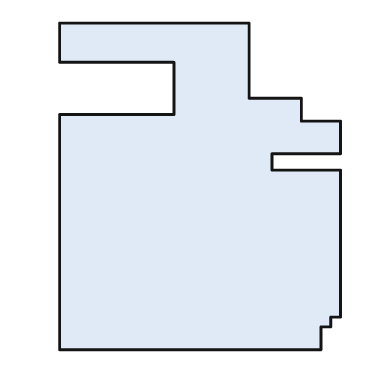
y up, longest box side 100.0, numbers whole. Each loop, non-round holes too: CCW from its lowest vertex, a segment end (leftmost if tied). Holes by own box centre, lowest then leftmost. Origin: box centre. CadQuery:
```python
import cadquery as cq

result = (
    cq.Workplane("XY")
    .moveTo(-43.0, -50.0)
    .lineTo(37.0, -50.0)
    .lineTo(37.0, -43.0)
    .lineTo(40.0, -43.0)
    .lineTo(40.0, -40.0)
    .lineTo(43.0, -40.0)
    .lineTo(43.0, 5.0)
    .lineTo(22.0, 5.0)
    .lineTo(22.0, 10.0)
    .lineTo(43.0, 10.0)
    .lineTo(43.0, 20.0)
    .lineTo(31.0, 20.0)
    .lineTo(31.0, 27.0)
    .lineTo(15.0, 27.0)
    .lineTo(15.0, 50.0)
    .lineTo(-43.0, 50.0)
    .lineTo(-43.0, 38.0)
    .lineTo(-8.0, 38.0)
    .lineTo(-8.0, 22.0)
    .lineTo(-43.0, 22.0)
    .close()
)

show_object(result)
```